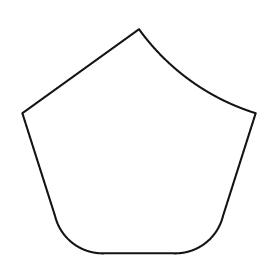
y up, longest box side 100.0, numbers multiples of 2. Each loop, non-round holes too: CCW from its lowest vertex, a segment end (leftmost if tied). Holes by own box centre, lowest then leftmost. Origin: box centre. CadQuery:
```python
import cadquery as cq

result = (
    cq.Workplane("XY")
    .moveTo(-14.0, -48.0)
    .lineTo(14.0, -48.0)
    .threePointArc((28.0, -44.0), (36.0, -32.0))
    .lineTo(50.0, 12.0)
    .threePointArc((22.0, 26.0), (0.0, 48.0))
    .lineTo(-50.0, 12.0)
    .lineTo(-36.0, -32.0)
    .threePointArc((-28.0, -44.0), (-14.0, -48.0))
    .close()
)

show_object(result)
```